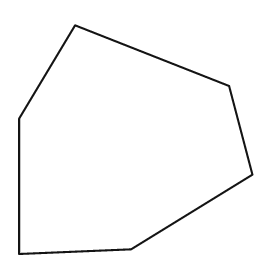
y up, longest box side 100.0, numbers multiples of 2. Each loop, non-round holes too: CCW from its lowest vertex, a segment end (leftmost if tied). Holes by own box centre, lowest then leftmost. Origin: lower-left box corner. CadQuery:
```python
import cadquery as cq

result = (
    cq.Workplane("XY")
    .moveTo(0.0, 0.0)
    .lineTo(48.0, 2.0)
    .lineTo(100.0, 34.0)
    .lineTo(90.0, 72.0)
    .lineTo(24.0, 98.0)
    .lineTo(0.0, 58.0)
    .close()
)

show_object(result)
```